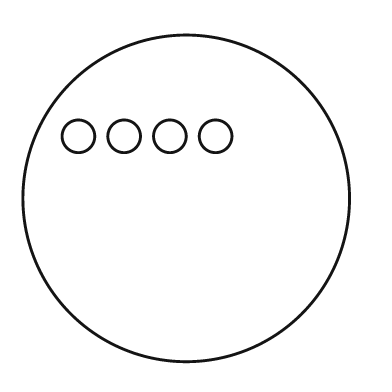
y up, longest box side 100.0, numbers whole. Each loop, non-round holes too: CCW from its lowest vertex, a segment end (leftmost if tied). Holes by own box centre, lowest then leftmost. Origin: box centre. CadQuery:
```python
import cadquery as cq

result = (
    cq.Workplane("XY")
    .moveTo(0.0, 0.0)
    .circle(50.0)
    .moveTo(-33.0, 19.0)
    .circle(5.0)
    .moveTo(-19.0, 19.0)
    .circle(5.0)
    .moveTo(-5.0, 19.0)
    .circle(5.0)
    .moveTo(9.0, 19.0)
    .circle(5.0)
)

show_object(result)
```